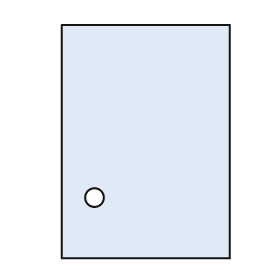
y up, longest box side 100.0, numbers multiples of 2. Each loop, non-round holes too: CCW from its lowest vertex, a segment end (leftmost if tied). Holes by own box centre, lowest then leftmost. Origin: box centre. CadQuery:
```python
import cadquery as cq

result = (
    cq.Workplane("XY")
    .moveTo(-36.0, -50.0)
    .lineTo(36.0, -50.0)
    .lineTo(36.0, 50.0)
    .lineTo(-36.0, 50.0)
    .close()
    .moveTo(-22.0, -24.0)
    .circle(4.0)
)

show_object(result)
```